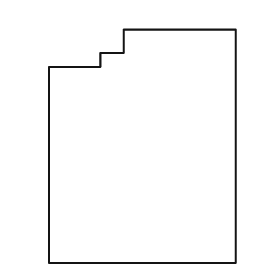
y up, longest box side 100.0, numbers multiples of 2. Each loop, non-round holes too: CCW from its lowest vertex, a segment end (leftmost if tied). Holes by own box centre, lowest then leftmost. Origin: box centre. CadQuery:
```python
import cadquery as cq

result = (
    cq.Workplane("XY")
    .moveTo(-40.0, -50.0)
    .lineTo(40.0, -50.0)
    .lineTo(40.0, 50.0)
    .lineTo(-8.0, 50.0)
    .lineTo(-8.0, 40.0)
    .lineTo(-18.0, 40.0)
    .lineTo(-18.0, 34.0)
    .lineTo(-40.0, 34.0)
    .close()
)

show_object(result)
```